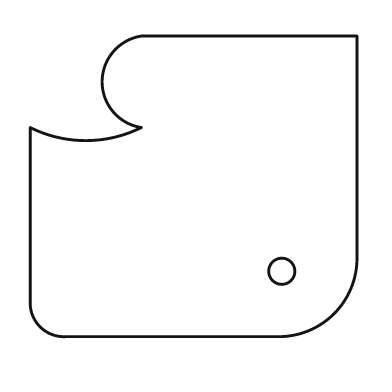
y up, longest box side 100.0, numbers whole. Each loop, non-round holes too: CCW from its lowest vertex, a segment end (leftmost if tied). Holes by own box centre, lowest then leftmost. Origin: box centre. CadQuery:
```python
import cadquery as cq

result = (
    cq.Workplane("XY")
    .moveTo(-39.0, -46.0)
    .lineTo(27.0, -46.0)
    .threePointArc((43.0, -39.0), (50.0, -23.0))
    .lineTo(50.0, 46.0)
    .lineTo(-16.0, 46.0)
    .threePointArc((-28.0, 32.0), (-16.0, 18.0))
    .threePointArc((-33.0, 14.0), (-50.0, 18.0))
    .lineTo(-50.0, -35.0)
    .threePointArc((-47.0, -43.0), (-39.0, -46.0))
    .close()
    .moveTo(27.0, -26.0)
    .circle(4.0)
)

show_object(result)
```